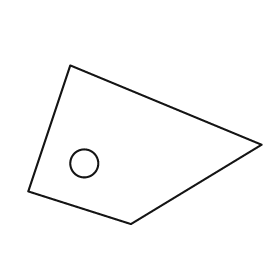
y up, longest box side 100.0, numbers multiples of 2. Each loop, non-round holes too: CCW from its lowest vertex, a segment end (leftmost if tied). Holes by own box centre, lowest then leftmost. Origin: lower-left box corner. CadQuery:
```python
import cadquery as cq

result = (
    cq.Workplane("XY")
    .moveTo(44.0, 0.0)
    .lineTo(100.0, 34.0)
    .lineTo(18.0, 68.0)
    .lineTo(0.0, 14.0)
    .close()
    .moveTo(24.0, 26.0)
    .circle(6.0)
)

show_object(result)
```